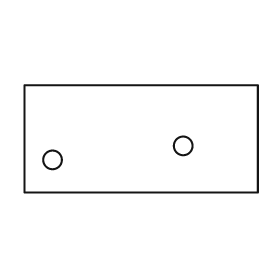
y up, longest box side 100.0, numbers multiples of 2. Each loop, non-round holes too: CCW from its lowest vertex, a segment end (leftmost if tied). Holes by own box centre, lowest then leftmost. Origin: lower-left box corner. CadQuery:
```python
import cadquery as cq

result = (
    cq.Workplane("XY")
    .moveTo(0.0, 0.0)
    .lineTo(100.0, 0.0)
    .lineTo(100.0, 46.0)
    .lineTo(0.0, 46.0)
    .close()
    .moveTo(12.0, 14.0)
    .circle(4.0)
    .moveTo(68.0, 20.0)
    .circle(4.0)
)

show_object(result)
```